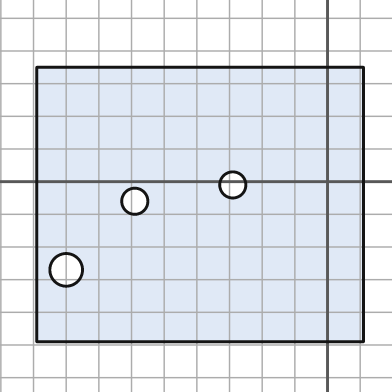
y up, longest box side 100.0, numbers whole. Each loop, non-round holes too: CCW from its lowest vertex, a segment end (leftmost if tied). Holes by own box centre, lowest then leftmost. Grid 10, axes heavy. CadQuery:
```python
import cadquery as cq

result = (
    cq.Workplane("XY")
    .moveTo(-89.0, -49.0)
    .lineTo(11.0, -49.0)
    .lineTo(11.0, 35.0)
    .lineTo(-89.0, 35.0)
    .close()
    .moveTo(-80.0, -27.0)
    .circle(5.0)
    .moveTo(-59.0, -6.0)
    .circle(4.0)
    .moveTo(-29.0, -1.0)
    .circle(4.0)
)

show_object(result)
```